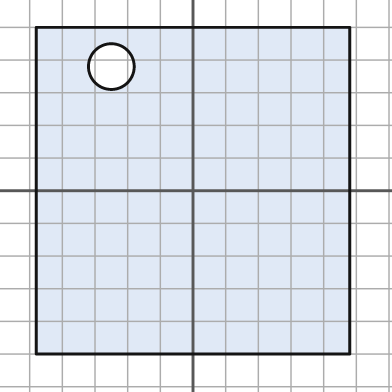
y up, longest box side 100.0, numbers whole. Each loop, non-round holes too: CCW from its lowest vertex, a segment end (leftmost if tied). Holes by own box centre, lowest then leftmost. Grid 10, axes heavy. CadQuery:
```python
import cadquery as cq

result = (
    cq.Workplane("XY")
    .moveTo(-48.0, -50.0)
    .lineTo(48.0, -50.0)
    .lineTo(48.0, 50.0)
    .lineTo(-48.0, 50.0)
    .close()
    .moveTo(-25.0, 38.0)
    .circle(7.0)
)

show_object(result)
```